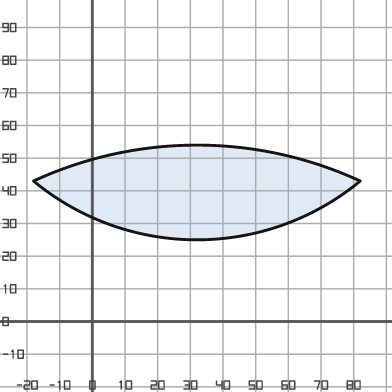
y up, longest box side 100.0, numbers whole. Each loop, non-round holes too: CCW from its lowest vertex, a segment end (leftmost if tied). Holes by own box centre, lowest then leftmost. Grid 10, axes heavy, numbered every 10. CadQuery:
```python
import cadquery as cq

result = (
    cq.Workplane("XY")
    .moveTo(-18.0, 43.0)
    .threePointArc((32.0, 25.0), (82.0, 43.0))
    .threePointArc((32.0, 54.0), (-18.0, 43.0))
    .close()
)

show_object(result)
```